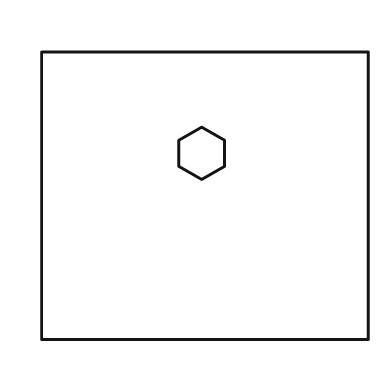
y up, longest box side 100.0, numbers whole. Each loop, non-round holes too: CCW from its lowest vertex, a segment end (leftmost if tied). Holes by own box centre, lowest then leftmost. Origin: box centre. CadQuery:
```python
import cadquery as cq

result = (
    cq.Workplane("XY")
    .moveTo(-50.0, -44.0)
    .lineTo(50.0, -44.0)
    .lineTo(50.0, 44.0)
    .lineTo(-50.0, 44.0)
    .close()
    .moveTo(-1.0, 5.0)
    .lineTo(6.0, 9.0)
    .lineTo(6.0, 17.0)
    .lineTo(-1.0, 21.0)
    .lineTo(-8.0, 17.0)
    .lineTo(-8.0, 9.0)
    .close()
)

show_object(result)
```